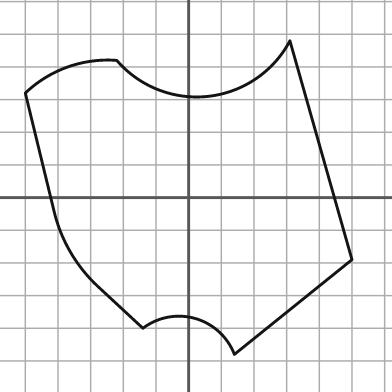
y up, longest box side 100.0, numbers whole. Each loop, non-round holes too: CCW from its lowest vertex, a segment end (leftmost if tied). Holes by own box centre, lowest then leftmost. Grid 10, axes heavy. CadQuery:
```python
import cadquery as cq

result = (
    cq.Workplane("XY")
    .moveTo(14.0, -48.0)
    .lineTo(50.0, -19.0)
    .lineTo(31.0, 48.0)
    .threePointArc((6.0, 31.0), (-22.0, 42.0))
    .threePointArc((-37.0, 40.0), (-50.0, 32.0))
    .lineTo(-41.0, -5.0)
    .threePointArc((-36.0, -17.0), (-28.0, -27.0))
    .lineTo(-14.0, -40.0)
    .threePointArc((2.0, -37.0), (14.0, -48.0))
    .close()
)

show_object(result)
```